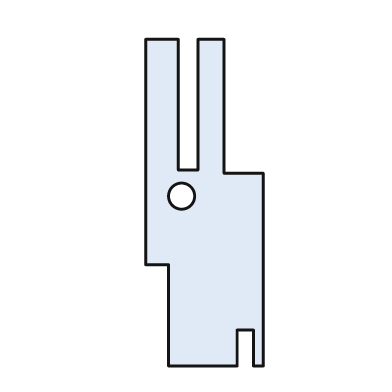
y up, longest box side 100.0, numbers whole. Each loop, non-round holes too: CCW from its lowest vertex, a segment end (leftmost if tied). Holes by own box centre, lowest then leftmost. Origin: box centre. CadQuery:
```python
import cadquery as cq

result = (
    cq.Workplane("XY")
    .moveTo(-11.0, -50.0)
    .lineTo(10.0, -50.0)
    .lineTo(10.0, -39.0)
    .lineTo(15.0, -39.0)
    .lineTo(15.0, -50.0)
    .lineTo(18.0, -50.0)
    .lineTo(18.0, 9.0)
    .lineTo(6.0, 9.0)
    .lineTo(6.0, 50.0)
    .lineTo(-2.0, 50.0)
    .lineTo(-2.0, 10.0)
    .lineTo(-8.0, 10.0)
    .lineTo(-8.0, 50.0)
    .lineTo(-18.0, 50.0)
    .lineTo(-18.0, -19.0)
    .lineTo(-11.0, -19.0)
    .close()
    .moveTo(-7.0, 2.0)
    .circle(4.0)
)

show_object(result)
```